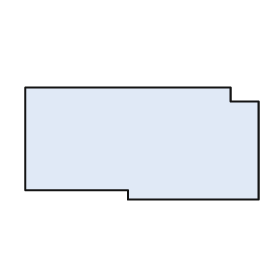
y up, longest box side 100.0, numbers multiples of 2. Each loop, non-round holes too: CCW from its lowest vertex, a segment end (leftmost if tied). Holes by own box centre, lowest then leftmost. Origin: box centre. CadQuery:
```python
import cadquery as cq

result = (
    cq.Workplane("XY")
    .moveTo(-6.0, -24.0)
    .lineTo(50.0, -24.0)
    .lineTo(50.0, 18.0)
    .lineTo(38.0, 18.0)
    .lineTo(38.0, 24.0)
    .lineTo(-50.0, 24.0)
    .lineTo(-50.0, -20.0)
    .lineTo(-6.0, -20.0)
    .close()
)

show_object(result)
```